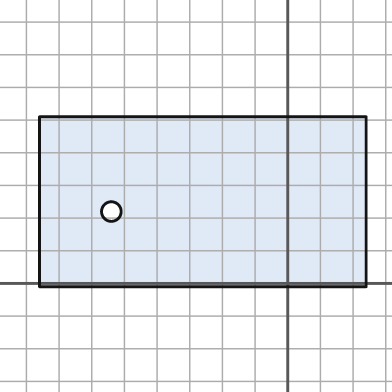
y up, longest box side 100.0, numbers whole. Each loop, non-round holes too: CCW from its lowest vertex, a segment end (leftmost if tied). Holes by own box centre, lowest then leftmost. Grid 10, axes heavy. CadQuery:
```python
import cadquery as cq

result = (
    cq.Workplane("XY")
    .moveTo(-76.0, -1.0)
    .lineTo(24.0, -1.0)
    .lineTo(24.0, 51.0)
    .lineTo(-76.0, 51.0)
    .close()
    .moveTo(-54.0, 22.0)
    .circle(3.0)
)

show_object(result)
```